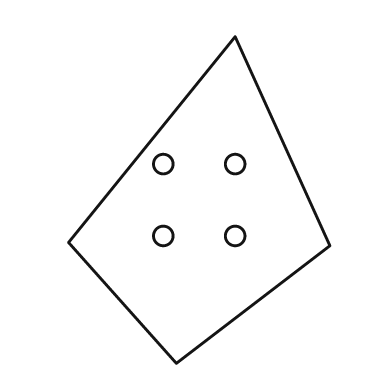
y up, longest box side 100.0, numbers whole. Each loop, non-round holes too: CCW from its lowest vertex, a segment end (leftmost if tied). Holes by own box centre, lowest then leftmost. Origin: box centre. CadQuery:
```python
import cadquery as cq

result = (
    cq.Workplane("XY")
    .moveTo(-7.0, -50.0)
    .lineTo(40.0, -14.0)
    .lineTo(11.0, 50.0)
    .lineTo(-40.0, -13.0)
    .close()
    .moveTo(-11.0, -11.0)
    .circle(3.0)
    .moveTo(11.0, -11.0)
    .circle(3.0)
    .moveTo(-11.0, 11.0)
    .circle(3.0)
    .moveTo(11.0, 11.0)
    .circle(3.0)
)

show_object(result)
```